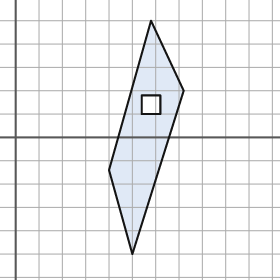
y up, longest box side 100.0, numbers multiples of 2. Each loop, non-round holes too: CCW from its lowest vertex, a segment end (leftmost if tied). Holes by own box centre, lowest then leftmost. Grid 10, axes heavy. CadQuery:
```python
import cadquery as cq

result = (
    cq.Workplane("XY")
    .moveTo(50.0, -50.0)
    .lineTo(72.0, 20.0)
    .lineTo(58.0, 50.0)
    .lineTo(40.0, -14.0)
    .close()
    .moveTo(54.0, 10.0)
    .lineTo(62.0, 10.0)
    .lineTo(62.0, 18.0)
    .lineTo(54.0, 18.0)
    .close()
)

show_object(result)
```